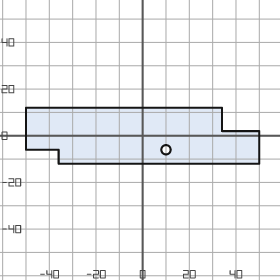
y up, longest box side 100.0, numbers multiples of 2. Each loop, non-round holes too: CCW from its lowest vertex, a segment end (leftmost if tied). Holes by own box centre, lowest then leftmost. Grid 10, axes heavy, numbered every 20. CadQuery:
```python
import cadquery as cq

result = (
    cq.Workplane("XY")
    .moveTo(-36.0, -12.0)
    .lineTo(50.0, -12.0)
    .lineTo(50.0, 2.0)
    .lineTo(34.0, 2.0)
    .lineTo(34.0, 12.0)
    .lineTo(-50.0, 12.0)
    .lineTo(-50.0, -6.0)
    .lineTo(-36.0, -6.0)
    .close()
    .moveTo(10.0, -6.0)
    .circle(2.0)
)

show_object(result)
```